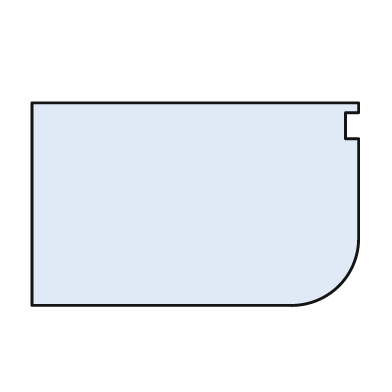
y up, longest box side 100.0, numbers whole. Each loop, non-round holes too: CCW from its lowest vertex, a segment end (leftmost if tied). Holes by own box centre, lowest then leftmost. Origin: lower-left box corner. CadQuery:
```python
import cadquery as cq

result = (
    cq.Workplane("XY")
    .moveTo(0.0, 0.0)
    .lineTo(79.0, 0.0)
    .threePointArc((94.0, 6.0), (100.0, 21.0))
    .lineTo(100.0, 51.0)
    .lineTo(96.0, 51.0)
    .lineTo(96.0, 59.0)
    .lineTo(100.0, 59.0)
    .lineTo(100.0, 62.0)
    .lineTo(0.0, 62.0)
    .close()
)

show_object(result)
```